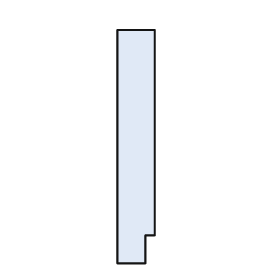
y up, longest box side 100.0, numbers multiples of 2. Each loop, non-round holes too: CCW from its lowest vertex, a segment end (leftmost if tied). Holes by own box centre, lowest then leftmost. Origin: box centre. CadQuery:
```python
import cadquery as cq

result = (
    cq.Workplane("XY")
    .moveTo(-8.0, -50.0)
    .lineTo(4.0, -50.0)
    .lineTo(4.0, -38.0)
    .lineTo(8.0, -38.0)
    .lineTo(8.0, 50.0)
    .lineTo(-8.0, 50.0)
    .close()
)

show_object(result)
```